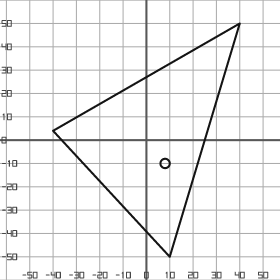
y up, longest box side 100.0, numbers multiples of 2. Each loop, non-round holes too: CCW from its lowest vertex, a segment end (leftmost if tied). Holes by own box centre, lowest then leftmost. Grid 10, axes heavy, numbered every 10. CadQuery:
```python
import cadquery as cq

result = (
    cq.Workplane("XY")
    .moveTo(10.0, -50.0)
    .lineTo(40.0, 50.0)
    .lineTo(-40.0, 4.0)
    .close()
    .moveTo(8.0, -10.0)
    .circle(2.0)
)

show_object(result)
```